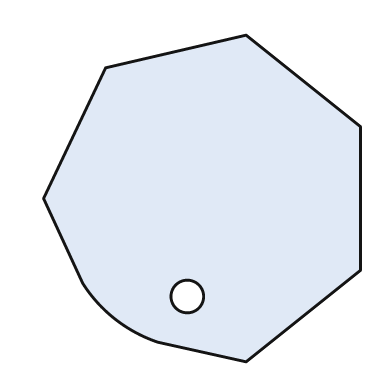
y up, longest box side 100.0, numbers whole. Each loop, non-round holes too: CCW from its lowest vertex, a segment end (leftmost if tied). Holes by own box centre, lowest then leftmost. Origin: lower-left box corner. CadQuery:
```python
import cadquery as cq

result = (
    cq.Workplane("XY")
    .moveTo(62.0, 0.0)
    .lineTo(97.0, 28.0)
    .lineTo(97.0, 72.0)
    .lineTo(62.0, 100.0)
    .lineTo(19.0, 90.0)
    .lineTo(0.0, 50.0)
    .lineTo(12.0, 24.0)
    .threePointArc((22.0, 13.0), (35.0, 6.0))
    .close()
    .moveTo(44.0, 20.0)
    .circle(5.0)
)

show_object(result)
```